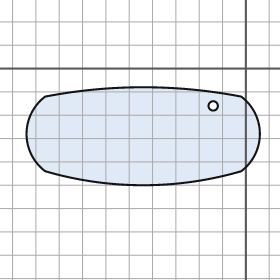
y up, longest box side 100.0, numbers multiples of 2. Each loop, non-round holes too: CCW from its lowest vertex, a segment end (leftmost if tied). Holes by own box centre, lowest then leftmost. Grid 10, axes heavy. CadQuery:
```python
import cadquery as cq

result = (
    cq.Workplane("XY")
    .moveTo(-86.0, -44.0)
    .threePointArc((-44.0, -50.0), (-2.0, -44.0))
    .threePointArc((6.0, -28.0), (-2.0, -12.0))
    .threePointArc((-44.0, -8.0), (-86.0, -12.0))
    .threePointArc((-94.0, -28.0), (-86.0, -44.0))
    .close()
    .moveTo(-14.0, -16.0)
    .circle(2.0)
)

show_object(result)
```